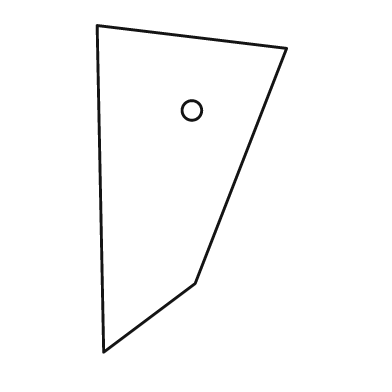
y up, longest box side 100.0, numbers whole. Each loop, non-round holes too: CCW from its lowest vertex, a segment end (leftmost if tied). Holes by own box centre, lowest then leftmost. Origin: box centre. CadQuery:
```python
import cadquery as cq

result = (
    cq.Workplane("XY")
    .moveTo(-27.0, -50.0)
    .lineTo(1.0, -29.0)
    .lineTo(29.0, 43.0)
    .lineTo(-29.0, 50.0)
    .close()
    .moveTo(0.0, 24.0)
    .circle(3.0)
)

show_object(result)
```